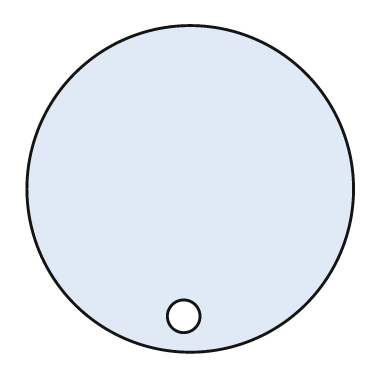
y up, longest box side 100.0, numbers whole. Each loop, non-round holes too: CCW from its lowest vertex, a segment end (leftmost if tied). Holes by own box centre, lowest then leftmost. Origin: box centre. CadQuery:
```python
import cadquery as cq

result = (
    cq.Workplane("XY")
    .moveTo(0.0, 0.0)
    .circle(50.0)
    .moveTo(-2.0, -39.0)
    .circle(5.0)
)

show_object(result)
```